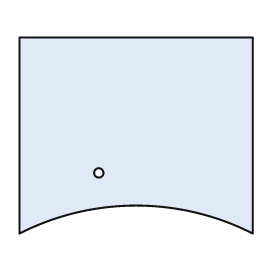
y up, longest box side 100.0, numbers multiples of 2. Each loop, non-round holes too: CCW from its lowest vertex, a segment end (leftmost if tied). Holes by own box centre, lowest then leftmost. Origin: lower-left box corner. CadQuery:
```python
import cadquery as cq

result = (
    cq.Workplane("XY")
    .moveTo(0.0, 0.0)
    .threePointArc((50.0, 12.0), (100.0, 0.0))
    .lineTo(100.0, 84.0)
    .lineTo(0.0, 84.0)
    .close()
    .moveTo(34.0, 26.0)
    .circle(2.0)
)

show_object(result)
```